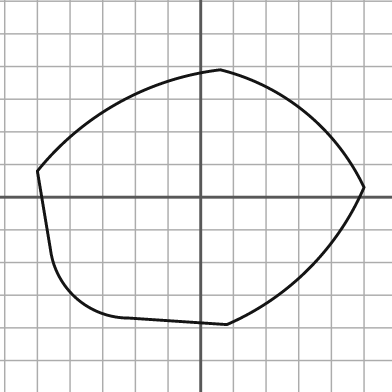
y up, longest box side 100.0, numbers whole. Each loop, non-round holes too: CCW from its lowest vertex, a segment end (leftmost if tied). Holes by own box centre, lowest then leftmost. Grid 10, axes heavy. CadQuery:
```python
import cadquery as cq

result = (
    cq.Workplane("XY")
    .moveTo(8.0, -39.0)
    .threePointArc((33.0, -22.0), (50.0, 3.0))
    .threePointArc((32.0, 26.0), (6.0, 39.0))
    .threePointArc((-25.0, 29.0), (-50.0, 8.0))
    .lineTo(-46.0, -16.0)
    .threePointArc((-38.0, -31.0), (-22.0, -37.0))
    .close()
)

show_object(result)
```